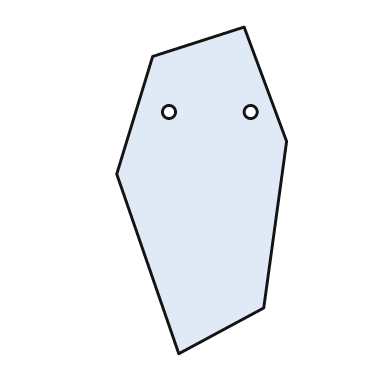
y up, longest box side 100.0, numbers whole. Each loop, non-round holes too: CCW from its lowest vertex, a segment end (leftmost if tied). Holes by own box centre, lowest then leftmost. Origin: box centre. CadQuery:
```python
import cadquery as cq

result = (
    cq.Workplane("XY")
    .moveTo(-7.0, -50.0)
    .lineTo(19.0, -36.0)
    .lineTo(26.0, 15.0)
    .lineTo(13.0, 50.0)
    .lineTo(-15.0, 41.0)
    .lineTo(-26.0, 5.0)
    .close()
    .moveTo(-10.0, 24.0)
    .circle(2.0)
    .moveTo(15.0, 24.0)
    .circle(2.0)
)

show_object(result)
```